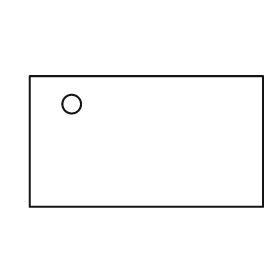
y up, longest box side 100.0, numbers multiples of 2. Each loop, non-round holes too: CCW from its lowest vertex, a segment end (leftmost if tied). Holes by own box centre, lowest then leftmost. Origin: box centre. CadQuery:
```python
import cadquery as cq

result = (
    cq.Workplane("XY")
    .moveTo(-50.0, -28.0)
    .lineTo(50.0, -28.0)
    .lineTo(50.0, 28.0)
    .lineTo(-50.0, 28.0)
    .close()
    .moveTo(-32.0, 16.0)
    .circle(4.0)
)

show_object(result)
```